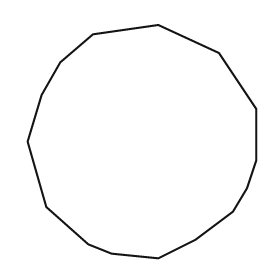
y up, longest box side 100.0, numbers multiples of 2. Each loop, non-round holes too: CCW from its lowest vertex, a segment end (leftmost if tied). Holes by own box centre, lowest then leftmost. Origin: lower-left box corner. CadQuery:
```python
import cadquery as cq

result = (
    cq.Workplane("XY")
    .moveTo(56.0, 0.0)
    .lineTo(72.0, 8.0)
    .lineTo(88.0, 20.0)
    .lineTo(94.0, 30.0)
    .lineTo(98.0, 42.0)
    .lineTo(98.0, 64.0)
    .lineTo(82.0, 88.0)
    .lineTo(56.0, 100.0)
    .lineTo(28.0, 96.0)
    .lineTo(14.0, 84.0)
    .lineTo(6.0, 70.0)
    .lineTo(0.0, 50.0)
    .lineTo(8.0, 22.0)
    .lineTo(26.0, 6.0)
    .lineTo(36.0, 2.0)
    .close()
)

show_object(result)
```